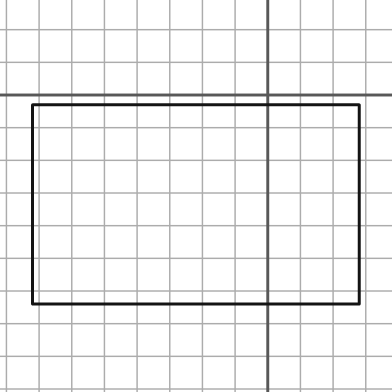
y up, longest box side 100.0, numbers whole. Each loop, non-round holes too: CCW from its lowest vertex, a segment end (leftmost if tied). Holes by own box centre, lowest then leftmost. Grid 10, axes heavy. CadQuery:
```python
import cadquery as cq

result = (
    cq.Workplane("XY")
    .moveTo(-72.0, -64.0)
    .lineTo(28.0, -64.0)
    .lineTo(28.0, -3.0)
    .lineTo(-72.0, -3.0)
    .close()
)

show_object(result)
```